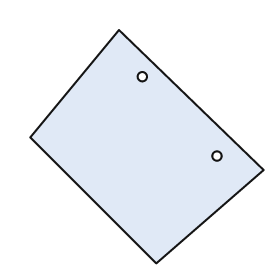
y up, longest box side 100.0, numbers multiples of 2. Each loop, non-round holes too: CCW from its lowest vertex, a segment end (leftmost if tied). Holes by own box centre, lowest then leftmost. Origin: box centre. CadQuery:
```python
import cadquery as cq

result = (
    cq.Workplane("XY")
    .moveTo(4.0, -50.0)
    .lineTo(50.0, -10.0)
    .lineTo(-12.0, 50.0)
    .lineTo(-50.0, 4.0)
    .close()
    .moveTo(30.0, -4.0)
    .circle(2.0)
    .moveTo(-2.0, 30.0)
    .circle(2.0)
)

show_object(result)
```